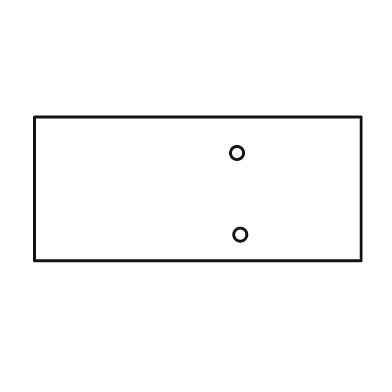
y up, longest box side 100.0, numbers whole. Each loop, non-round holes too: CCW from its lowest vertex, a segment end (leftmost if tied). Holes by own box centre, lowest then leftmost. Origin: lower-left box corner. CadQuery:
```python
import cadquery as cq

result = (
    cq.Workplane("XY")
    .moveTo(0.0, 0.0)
    .lineTo(100.0, 0.0)
    .lineTo(100.0, 44.0)
    .lineTo(0.0, 44.0)
    .close()
    .moveTo(63.0, 8.0)
    .circle(2.0)
    .moveTo(62.0, 33.0)
    .circle(2.0)
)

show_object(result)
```